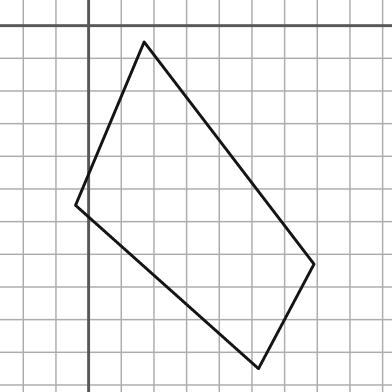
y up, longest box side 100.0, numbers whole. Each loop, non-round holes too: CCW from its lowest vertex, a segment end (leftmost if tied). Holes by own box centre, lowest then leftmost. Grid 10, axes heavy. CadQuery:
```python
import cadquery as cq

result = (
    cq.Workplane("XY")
    .moveTo(52.0, -105.0)
    .lineTo(69.0, -73.0)
    .lineTo(17.0, -5.0)
    .lineTo(-4.0, -55.0)
    .close()
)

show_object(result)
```